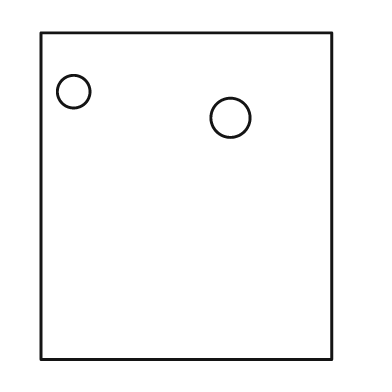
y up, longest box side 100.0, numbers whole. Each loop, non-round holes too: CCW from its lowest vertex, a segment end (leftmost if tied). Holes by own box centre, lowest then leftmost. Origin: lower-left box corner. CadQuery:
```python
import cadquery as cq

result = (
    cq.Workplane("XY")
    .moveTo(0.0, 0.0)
    .lineTo(89.0, 0.0)
    .lineTo(89.0, 100.0)
    .lineTo(0.0, 100.0)
    .close()
    .moveTo(58.0, 74.0)
    .circle(6.0)
    .moveTo(10.0, 82.0)
    .circle(5.0)
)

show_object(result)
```